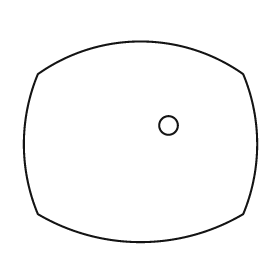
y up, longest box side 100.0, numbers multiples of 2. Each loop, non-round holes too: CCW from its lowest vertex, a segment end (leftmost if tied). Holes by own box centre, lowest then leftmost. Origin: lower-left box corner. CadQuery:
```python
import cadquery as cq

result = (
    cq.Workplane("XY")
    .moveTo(6.0, 12.0)
    .threePointArc((50.0, 0.0), (94.0, 12.0))
    .threePointArc((100.0, 42.0), (94.0, 72.0))
    .threePointArc((50.0, 86.0), (6.0, 72.0))
    .threePointArc((0.0, 42.0), (6.0, 12.0))
    .close()
    .moveTo(62.0, 50.0)
    .circle(4.0)
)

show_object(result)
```